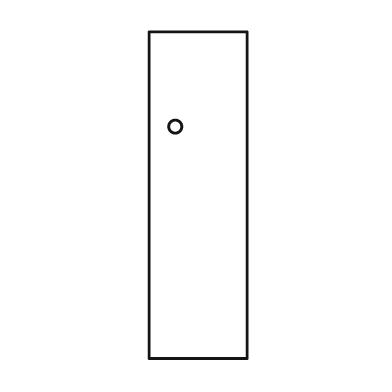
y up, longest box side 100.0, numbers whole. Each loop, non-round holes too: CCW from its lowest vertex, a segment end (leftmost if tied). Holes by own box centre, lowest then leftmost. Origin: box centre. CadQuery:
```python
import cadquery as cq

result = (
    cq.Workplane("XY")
    .moveTo(-15.0, -50.0)
    .lineTo(15.0, -50.0)
    .lineTo(15.0, 50.0)
    .lineTo(-15.0, 50.0)
    .close()
    .moveTo(-7.0, 21.0)
    .circle(2.0)
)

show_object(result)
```